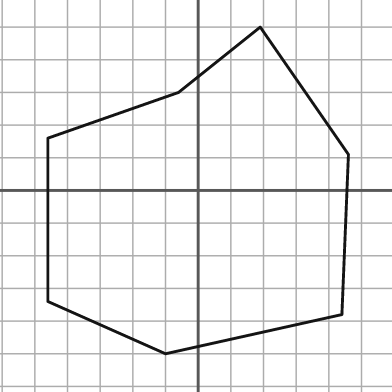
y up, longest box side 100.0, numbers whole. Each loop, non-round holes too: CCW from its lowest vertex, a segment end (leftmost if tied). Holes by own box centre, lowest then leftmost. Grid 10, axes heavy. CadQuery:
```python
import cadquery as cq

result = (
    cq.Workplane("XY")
    .moveTo(-10.0, -50.0)
    .lineTo(44.0, -38.0)
    .lineTo(46.0, 11.0)
    .lineTo(19.0, 50.0)
    .lineTo(-6.0, 30.0)
    .lineTo(-46.0, 16.0)
    .lineTo(-46.0, -34.0)
    .close()
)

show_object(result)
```